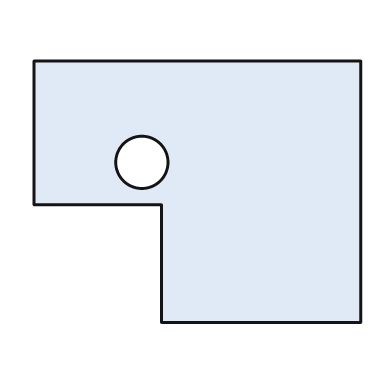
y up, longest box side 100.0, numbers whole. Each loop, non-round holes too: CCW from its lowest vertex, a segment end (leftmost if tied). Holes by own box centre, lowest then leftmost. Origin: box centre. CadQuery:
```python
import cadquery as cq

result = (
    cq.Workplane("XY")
    .moveTo(-11.0, -40.0)
    .lineTo(50.0, -40.0)
    .lineTo(50.0, 40.0)
    .lineTo(-50.0, 40.0)
    .lineTo(-50.0, -4.0)
    .lineTo(-11.0, -4.0)
    .close()
    .moveTo(-17.0, 9.0)
    .circle(8.0)
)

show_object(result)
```